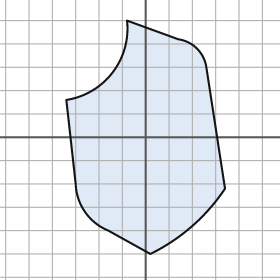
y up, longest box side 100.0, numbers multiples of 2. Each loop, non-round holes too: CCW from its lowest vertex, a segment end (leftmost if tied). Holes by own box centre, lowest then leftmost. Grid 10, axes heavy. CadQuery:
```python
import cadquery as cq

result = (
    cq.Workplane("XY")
    .moveTo(2.0, -50.0)
    .threePointArc((20.0, -38.0), (34.0, -22.0))
    .lineTo(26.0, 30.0)
    .threePointArc((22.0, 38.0), (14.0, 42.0))
    .lineTo(-8.0, 50.0)
    .threePointArc((-14.0, 28.0), (-34.0, 16.0))
    .lineTo(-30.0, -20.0)
    .threePointArc((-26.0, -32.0), (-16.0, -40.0))
    .close()
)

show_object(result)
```